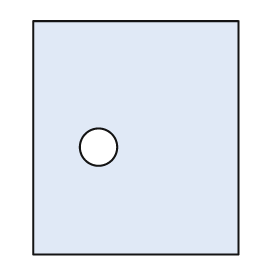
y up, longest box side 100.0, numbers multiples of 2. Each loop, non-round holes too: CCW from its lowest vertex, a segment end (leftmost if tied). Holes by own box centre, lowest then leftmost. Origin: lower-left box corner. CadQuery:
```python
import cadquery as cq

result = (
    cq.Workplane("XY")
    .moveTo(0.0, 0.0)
    .lineTo(88.0, 0.0)
    .lineTo(88.0, 100.0)
    .lineTo(0.0, 100.0)
    .close()
    .moveTo(28.0, 46.0)
    .circle(8.0)
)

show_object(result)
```